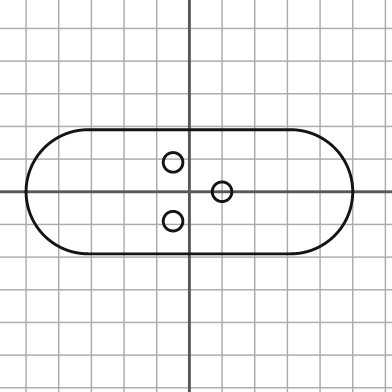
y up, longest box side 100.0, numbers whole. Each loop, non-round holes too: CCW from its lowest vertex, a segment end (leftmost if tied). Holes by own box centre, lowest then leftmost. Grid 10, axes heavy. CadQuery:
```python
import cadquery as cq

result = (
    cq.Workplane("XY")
    .moveTo(-31.0, -19.0)
    .lineTo(31.0, -19.0)
    .threePointArc((50.0, 0.0), (31.0, 19.0))
    .lineTo(-31.0, 19.0)
    .threePointArc((-50.0, 0.0), (-31.0, -19.0))
    .close()
    .moveTo(-5.0, -9.0)
    .circle(3.0)
    .moveTo(10.0, 0.0)
    .circle(3.0)
    .moveTo(-5.0, 9.0)
    .circle(3.0)
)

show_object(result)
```